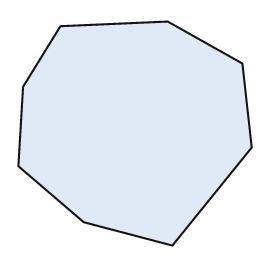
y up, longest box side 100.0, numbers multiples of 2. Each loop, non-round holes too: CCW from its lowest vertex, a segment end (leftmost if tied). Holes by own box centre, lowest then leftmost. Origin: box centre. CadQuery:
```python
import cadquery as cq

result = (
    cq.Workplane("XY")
    .moveTo(16.0, -48.0)
    .lineTo(50.0, -6.0)
    .lineTo(46.0, 30.0)
    .lineTo(14.0, 48.0)
    .lineTo(-32.0, 46.0)
    .lineTo(-48.0, 20.0)
    .lineTo(-50.0, -14.0)
    .lineTo(-22.0, -38.0)
    .close()
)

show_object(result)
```